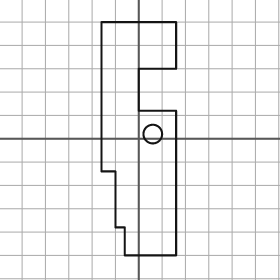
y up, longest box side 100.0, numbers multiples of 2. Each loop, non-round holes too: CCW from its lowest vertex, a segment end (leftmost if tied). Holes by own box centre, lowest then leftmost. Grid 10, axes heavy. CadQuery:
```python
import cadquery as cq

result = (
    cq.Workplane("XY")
    .moveTo(-6.0, -50.0)
    .lineTo(16.0, -50.0)
    .lineTo(16.0, 12.0)
    .lineTo(0.0, 12.0)
    .lineTo(0.0, 30.0)
    .lineTo(16.0, 30.0)
    .lineTo(16.0, 50.0)
    .lineTo(-16.0, 50.0)
    .lineTo(-16.0, -14.0)
    .lineTo(-10.0, -14.0)
    .lineTo(-10.0, -38.0)
    .lineTo(-6.0, -38.0)
    .close()
    .moveTo(6.0, 2.0)
    .circle(4.0)
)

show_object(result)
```